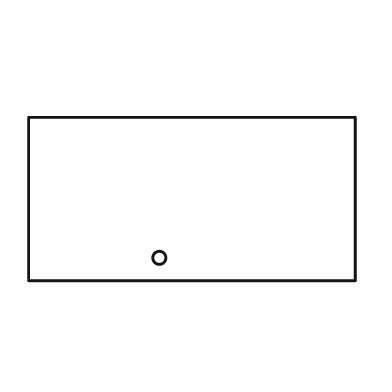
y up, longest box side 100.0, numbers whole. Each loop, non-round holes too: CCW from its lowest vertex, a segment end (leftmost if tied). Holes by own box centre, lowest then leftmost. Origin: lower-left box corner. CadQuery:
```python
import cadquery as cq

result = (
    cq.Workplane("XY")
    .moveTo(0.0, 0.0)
    .lineTo(100.0, 0.0)
    .lineTo(100.0, 50.0)
    .lineTo(0.0, 50.0)
    .close()
    .moveTo(40.0, 7.0)
    .circle(2.0)
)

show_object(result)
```